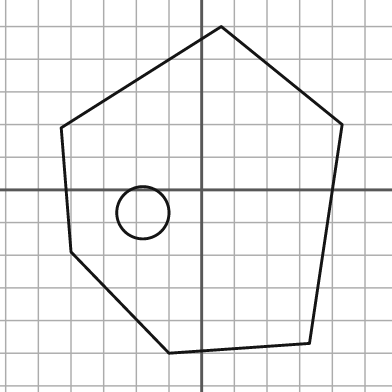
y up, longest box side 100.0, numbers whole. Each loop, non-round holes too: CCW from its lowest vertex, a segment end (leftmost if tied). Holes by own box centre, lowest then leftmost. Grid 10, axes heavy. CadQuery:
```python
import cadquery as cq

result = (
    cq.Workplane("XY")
    .moveTo(-10.0, -50.0)
    .lineTo(33.0, -47.0)
    .lineTo(43.0, 20.0)
    .lineTo(6.0, 50.0)
    .lineTo(-43.0, 19.0)
    .lineTo(-40.0, -19.0)
    .close()
    .moveTo(-18.0, -7.0)
    .circle(8.0)
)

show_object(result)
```